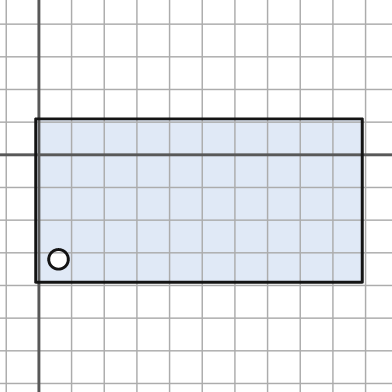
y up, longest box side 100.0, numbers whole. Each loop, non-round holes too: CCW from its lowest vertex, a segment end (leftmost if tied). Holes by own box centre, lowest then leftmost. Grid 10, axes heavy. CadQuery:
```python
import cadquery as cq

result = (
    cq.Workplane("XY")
    .moveTo(-1.0, -39.0)
    .lineTo(99.0, -39.0)
    .lineTo(99.0, 11.0)
    .lineTo(-1.0, 11.0)
    .close()
    .moveTo(6.0, -32.0)
    .circle(3.0)
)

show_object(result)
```